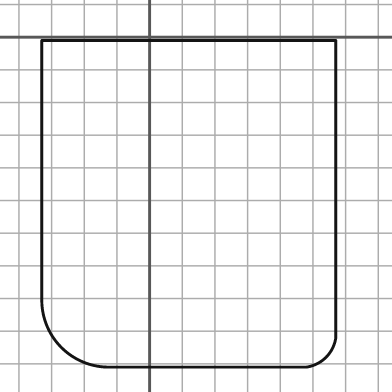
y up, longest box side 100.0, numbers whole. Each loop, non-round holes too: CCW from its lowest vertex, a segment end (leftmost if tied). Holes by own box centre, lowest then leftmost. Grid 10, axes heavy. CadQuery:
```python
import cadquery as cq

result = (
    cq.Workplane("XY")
    .moveTo(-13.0, -101.0)
    .lineTo(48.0, -101.0)
    .threePointArc((54.0, -98.0), (57.0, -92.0))
    .lineTo(57.0, -1.0)
    .lineTo(-33.0, -1.0)
    .lineTo(-33.0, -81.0)
    .threePointArc((-27.0, -95.0), (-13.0, -101.0))
    .close()
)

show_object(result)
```